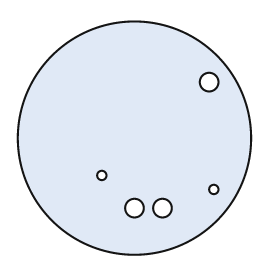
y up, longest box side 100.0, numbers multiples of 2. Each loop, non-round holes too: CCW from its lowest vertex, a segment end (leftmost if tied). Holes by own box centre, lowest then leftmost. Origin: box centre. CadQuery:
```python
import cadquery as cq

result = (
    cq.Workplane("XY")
    .moveTo(0.0, 0.0)
    .circle(50.0)
    .moveTo(0.0, -30.0)
    .circle(4.0)
    .moveTo(12.0, -30.0)
    .circle(4.0)
    .moveTo(34.0, -22.0)
    .circle(2.0)
    .moveTo(-14.0, -16.0)
    .circle(2.0)
    .moveTo(32.0, 24.0)
    .circle(4.0)
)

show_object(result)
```